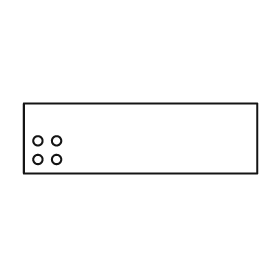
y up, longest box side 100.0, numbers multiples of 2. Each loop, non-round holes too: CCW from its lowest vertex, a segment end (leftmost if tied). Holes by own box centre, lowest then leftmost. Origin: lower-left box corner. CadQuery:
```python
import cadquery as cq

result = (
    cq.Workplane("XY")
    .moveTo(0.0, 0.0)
    .lineTo(100.0, 0.0)
    .lineTo(100.0, 30.0)
    .lineTo(0.0, 30.0)
    .close()
    .moveTo(6.0, 6.0)
    .circle(2.0)
    .moveTo(14.0, 6.0)
    .circle(2.0)
    .moveTo(6.0, 14.0)
    .circle(2.0)
    .moveTo(14.0, 14.0)
    .circle(2.0)
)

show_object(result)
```